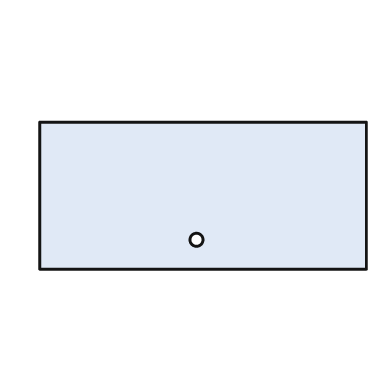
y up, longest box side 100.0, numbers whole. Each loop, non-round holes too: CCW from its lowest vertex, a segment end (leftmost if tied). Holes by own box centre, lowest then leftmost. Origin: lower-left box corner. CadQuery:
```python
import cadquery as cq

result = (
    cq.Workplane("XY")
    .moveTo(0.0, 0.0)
    .lineTo(100.0, 0.0)
    .lineTo(100.0, 45.0)
    .lineTo(0.0, 45.0)
    .close()
    .moveTo(48.0, 9.0)
    .circle(2.0)
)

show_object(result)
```